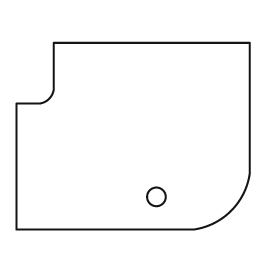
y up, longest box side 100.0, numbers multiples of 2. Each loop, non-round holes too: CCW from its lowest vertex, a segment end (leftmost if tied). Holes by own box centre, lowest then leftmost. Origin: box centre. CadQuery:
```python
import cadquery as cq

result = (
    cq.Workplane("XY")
    .moveTo(-50.0, -40.0)
    .lineTo(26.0, -40.0)
    .threePointArc((42.0, -32.0), (50.0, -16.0))
    .lineTo(50.0, 40.0)
    .lineTo(-34.0, 40.0)
    .lineTo(-34.0, 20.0)
    .threePointArc((-36.0, 16.0), (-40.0, 14.0))
    .lineTo(-50.0, 14.0)
    .close()
    .moveTo(10.0, -26.0)
    .circle(4.0)
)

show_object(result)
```